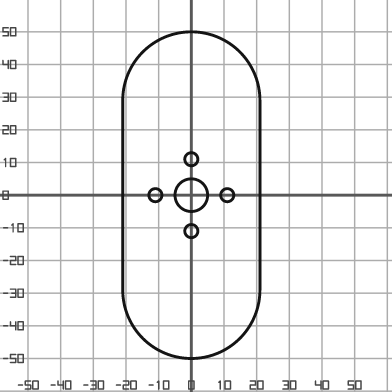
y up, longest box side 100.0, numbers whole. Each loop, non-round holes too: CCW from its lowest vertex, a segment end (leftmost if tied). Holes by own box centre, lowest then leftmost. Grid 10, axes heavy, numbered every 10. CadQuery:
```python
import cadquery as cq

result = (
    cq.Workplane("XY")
    .moveTo(-21.0, -29.0)
    .threePointArc((0.0, -50.0), (21.0, -29.0))
    .lineTo(21.0, 29.0)
    .threePointArc((0.0, 50.0), (-21.0, 29.0))
    .close()
    .moveTo(0.0, -11.0)
    .circle(2.0)
    .moveTo(-11.0, 0.0)
    .circle(2.0)
    .moveTo(0.0, 0.0)
    .circle(5.0)
    .moveTo(11.0, 0.0)
    .circle(2.0)
    .moveTo(0.0, 11.0)
    .circle(2.0)
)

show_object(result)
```